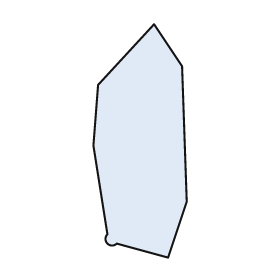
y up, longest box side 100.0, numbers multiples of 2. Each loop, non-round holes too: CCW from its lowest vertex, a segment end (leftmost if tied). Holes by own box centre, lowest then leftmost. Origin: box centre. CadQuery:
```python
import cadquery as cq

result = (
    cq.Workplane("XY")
    .moveTo(12.0, -50.0)
    .lineTo(20.0, -26.0)
    .lineTo(18.0, 32.0)
    .lineTo(6.0, 50.0)
    .lineTo(-18.0, 24.0)
    .lineTo(-20.0, -2.0)
    .lineTo(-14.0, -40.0)
    .threePointArc((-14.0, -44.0), (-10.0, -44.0))
    .close()
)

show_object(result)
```